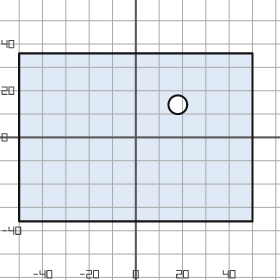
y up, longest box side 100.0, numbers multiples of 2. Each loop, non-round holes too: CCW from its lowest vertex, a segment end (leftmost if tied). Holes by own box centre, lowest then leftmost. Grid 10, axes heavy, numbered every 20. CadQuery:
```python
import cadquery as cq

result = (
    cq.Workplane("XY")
    .moveTo(-50.0, -36.0)
    .lineTo(50.0, -36.0)
    .lineTo(50.0, 36.0)
    .lineTo(-50.0, 36.0)
    .close()
    .moveTo(18.0, 14.0)
    .circle(4.0)
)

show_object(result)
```